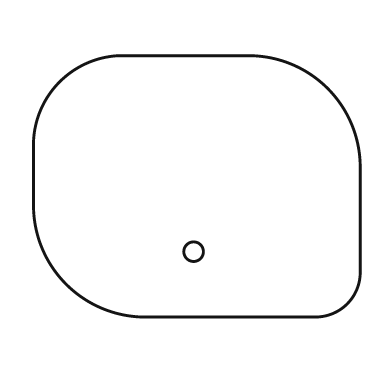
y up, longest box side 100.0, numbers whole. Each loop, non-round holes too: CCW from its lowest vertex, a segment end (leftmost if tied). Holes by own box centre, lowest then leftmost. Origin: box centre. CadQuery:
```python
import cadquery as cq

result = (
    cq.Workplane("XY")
    .moveTo(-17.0, -40.0)
    .lineTo(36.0, -40.0)
    .threePointArc((46.0, -36.0), (50.0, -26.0))
    .lineTo(50.0, 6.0)
    .threePointArc((40.0, 30.0), (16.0, 40.0))
    .lineTo(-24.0, 40.0)
    .threePointArc((-42.0, 32.0), (-50.0, 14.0))
    .lineTo(-50.0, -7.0)
    .threePointArc((-40.0, -30.0), (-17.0, -40.0))
    .close()
    .moveTo(-1.0, -20.0)
    .circle(3.0)
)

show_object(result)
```